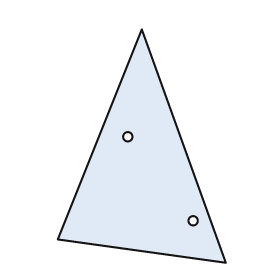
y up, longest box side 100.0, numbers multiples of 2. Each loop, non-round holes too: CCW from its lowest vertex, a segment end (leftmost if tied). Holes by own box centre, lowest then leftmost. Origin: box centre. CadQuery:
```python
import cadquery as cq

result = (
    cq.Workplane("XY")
    .moveTo(36.0, -50.0)
    .lineTo(0.0, 50.0)
    .lineTo(-36.0, -40.0)
    .close()
    .moveTo(22.0, -32.0)
    .circle(2.0)
    .moveTo(-6.0, 4.0)
    .circle(2.0)
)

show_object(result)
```